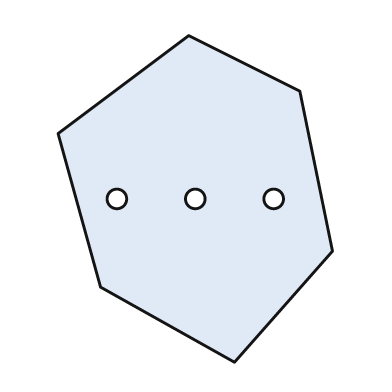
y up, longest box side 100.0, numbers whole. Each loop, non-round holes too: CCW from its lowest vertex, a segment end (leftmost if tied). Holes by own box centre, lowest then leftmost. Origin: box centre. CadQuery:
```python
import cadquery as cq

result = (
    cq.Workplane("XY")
    .moveTo(12.0, -50.0)
    .lineTo(42.0, -16.0)
    .lineTo(32.0, 33.0)
    .lineTo(-2.0, 50.0)
    .lineTo(-42.0, 20.0)
    .lineTo(-29.0, -27.0)
    .close()
    .moveTo(-24.0, 0.0)
    .circle(3.0)
    .moveTo(0.0, 0.0)
    .circle(3.0)
    .moveTo(24.0, 0.0)
    .circle(3.0)
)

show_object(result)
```